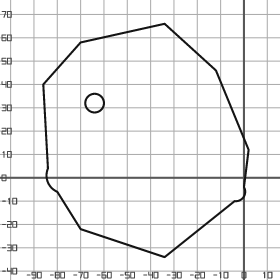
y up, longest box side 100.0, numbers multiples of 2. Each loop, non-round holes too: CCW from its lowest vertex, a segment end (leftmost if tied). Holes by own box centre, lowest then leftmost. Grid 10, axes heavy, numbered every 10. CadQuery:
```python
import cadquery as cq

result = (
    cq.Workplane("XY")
    .moveTo(-34.0, -34.0)
    .lineTo(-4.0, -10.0)
    .threePointArc((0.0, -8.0), (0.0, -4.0))
    .lineTo(2.0, 12.0)
    .lineTo(-12.0, 46.0)
    .lineTo(-34.0, 66.0)
    .lineTo(-70.0, 58.0)
    .lineTo(-86.0, 40.0)
    .lineTo(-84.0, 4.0)
    .threePointArc((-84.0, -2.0), (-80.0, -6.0))
    .lineTo(-70.0, -22.0)
    .close()
    .moveTo(-64.0, 32.0)
    .circle(4.0)
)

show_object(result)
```